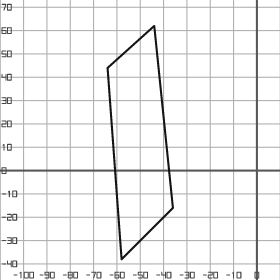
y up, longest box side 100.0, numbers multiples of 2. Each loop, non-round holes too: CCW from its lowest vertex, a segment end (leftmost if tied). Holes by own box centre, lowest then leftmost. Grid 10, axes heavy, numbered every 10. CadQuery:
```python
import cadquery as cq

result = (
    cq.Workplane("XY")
    .moveTo(-58.0, -38.0)
    .lineTo(-36.0, -16.0)
    .lineTo(-44.0, 62.0)
    .lineTo(-64.0, 44.0)
    .close()
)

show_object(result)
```